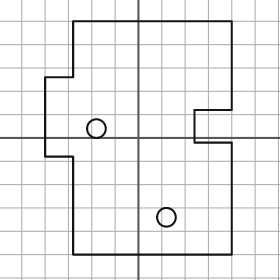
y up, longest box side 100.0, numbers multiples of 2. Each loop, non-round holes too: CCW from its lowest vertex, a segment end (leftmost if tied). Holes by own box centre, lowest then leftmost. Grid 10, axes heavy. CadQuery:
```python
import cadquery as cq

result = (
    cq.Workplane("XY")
    .moveTo(-28.0, -50.0)
    .lineTo(40.0, -50.0)
    .lineTo(40.0, -2.0)
    .lineTo(24.0, -2.0)
    .lineTo(24.0, 12.0)
    .lineTo(40.0, 12.0)
    .lineTo(40.0, 50.0)
    .lineTo(-28.0, 50.0)
    .lineTo(-28.0, 26.0)
    .lineTo(-40.0, 26.0)
    .lineTo(-40.0, -8.0)
    .lineTo(-28.0, -8.0)
    .close()
    .moveTo(12.0, -34.0)
    .circle(4.0)
    .moveTo(-18.0, 4.0)
    .circle(4.0)
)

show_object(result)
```